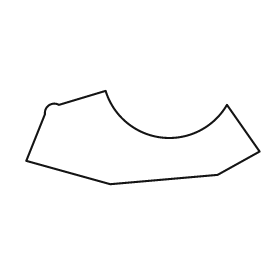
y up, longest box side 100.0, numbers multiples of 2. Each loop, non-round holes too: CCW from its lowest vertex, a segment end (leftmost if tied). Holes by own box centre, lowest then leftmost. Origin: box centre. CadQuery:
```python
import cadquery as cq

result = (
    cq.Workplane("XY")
    .moveTo(-14.0, -20.0)
    .lineTo(32.0, -16.0)
    .lineTo(50.0, -6.0)
    .lineTo(36.0, 14.0)
    .threePointArc((8.0, 0.0), (-16.0, 20.0))
    .lineTo(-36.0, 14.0)
    .threePointArc((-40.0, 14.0), (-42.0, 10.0))
    .lineTo(-50.0, -10.0)
    .close()
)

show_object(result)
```